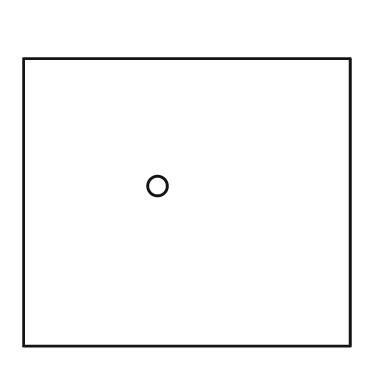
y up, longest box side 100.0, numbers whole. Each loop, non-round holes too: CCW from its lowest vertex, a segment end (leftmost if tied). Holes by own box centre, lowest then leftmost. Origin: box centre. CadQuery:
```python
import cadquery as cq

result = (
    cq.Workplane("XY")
    .moveTo(-50.0, -44.0)
    .lineTo(50.0, -44.0)
    .lineTo(50.0, 44.0)
    .lineTo(-50.0, 44.0)
    .close()
    .moveTo(-9.0, 5.0)
    .circle(3.0)
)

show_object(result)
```